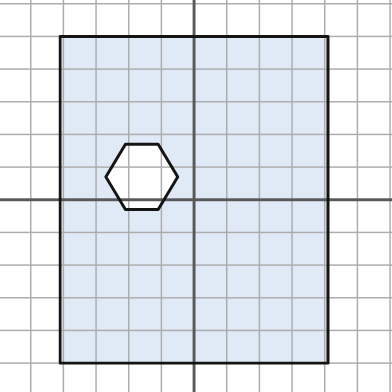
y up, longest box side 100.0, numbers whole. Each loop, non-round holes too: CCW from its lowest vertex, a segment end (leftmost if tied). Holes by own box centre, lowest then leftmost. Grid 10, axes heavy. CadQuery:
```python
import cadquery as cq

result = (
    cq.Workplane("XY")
    .moveTo(-41.0, -50.0)
    .lineTo(41.0, -50.0)
    .lineTo(41.0, 50.0)
    .lineTo(-41.0, 50.0)
    .close()
    .moveTo(-21.0, -3.0)
    .lineTo(-11.0, -3.0)
    .lineTo(-5.0, 7.0)
    .lineTo(-11.0, 17.0)
    .lineTo(-21.0, 17.0)
    .lineTo(-27.0, 7.0)
    .close()
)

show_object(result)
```